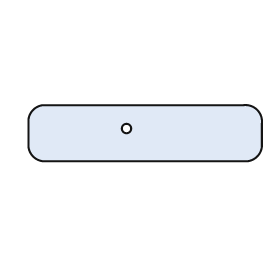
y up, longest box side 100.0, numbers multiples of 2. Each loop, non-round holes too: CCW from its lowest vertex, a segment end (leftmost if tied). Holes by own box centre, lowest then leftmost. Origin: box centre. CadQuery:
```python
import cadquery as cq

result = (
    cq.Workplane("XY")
    .moveTo(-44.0, -12.0)
    .lineTo(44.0, -12.0)
    .threePointArc((48.0, -10.0), (50.0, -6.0))
    .lineTo(50.0, 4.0)
    .threePointArc((48.0, 10.0), (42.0, 12.0))
    .lineTo(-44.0, 12.0)
    .threePointArc((-48.0, 10.0), (-50.0, 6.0))
    .lineTo(-50.0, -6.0)
    .threePointArc((-48.0, -10.0), (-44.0, -12.0))
    .close()
    .moveTo(-8.0, 2.0)
    .circle(2.0)
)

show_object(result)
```